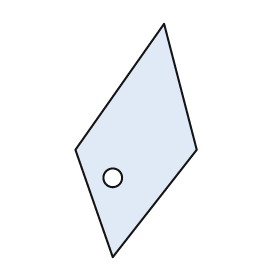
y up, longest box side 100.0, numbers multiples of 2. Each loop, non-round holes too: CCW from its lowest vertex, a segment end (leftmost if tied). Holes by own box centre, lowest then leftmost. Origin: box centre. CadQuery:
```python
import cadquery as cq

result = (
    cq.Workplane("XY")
    .moveTo(-10.0, -50.0)
    .lineTo(26.0, -4.0)
    .lineTo(12.0, 50.0)
    .lineTo(-26.0, -4.0)
    .close()
    .moveTo(-10.0, -16.0)
    .circle(4.0)
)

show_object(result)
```